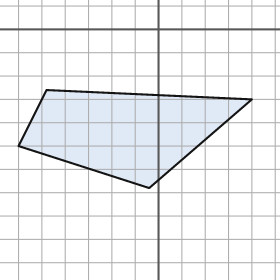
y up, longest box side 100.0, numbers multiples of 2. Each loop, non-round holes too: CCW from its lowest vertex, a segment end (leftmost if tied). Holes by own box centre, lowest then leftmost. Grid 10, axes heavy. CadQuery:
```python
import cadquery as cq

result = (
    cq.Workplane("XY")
    .moveTo(-4.0, -68.0)
    .lineTo(40.0, -30.0)
    .lineTo(-48.0, -26.0)
    .lineTo(-60.0, -50.0)
    .close()
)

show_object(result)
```